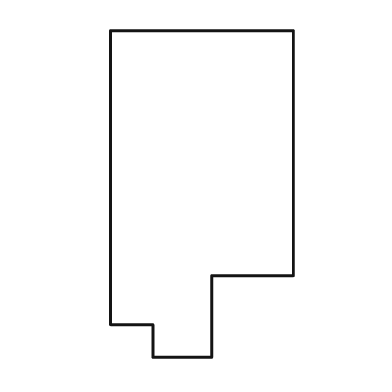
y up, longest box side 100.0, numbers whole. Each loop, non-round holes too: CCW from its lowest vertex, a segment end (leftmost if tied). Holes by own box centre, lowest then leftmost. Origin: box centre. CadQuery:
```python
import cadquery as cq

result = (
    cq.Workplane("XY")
    .moveTo(-15.0, -50.0)
    .lineTo(3.0, -50.0)
    .lineTo(3.0, -25.0)
    .lineTo(28.0, -25.0)
    .lineTo(28.0, 50.0)
    .lineTo(-28.0, 50.0)
    .lineTo(-28.0, -40.0)
    .lineTo(-15.0, -40.0)
    .close()
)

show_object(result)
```